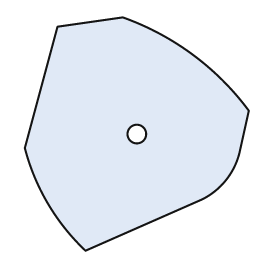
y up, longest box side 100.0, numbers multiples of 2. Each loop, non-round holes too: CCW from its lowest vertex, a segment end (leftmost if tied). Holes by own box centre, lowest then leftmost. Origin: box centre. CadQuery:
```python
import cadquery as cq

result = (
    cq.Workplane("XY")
    .moveTo(-22.0, -50.0)
    .lineTo(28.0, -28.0)
    .threePointArc((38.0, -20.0), (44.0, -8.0))
    .lineTo(48.0, 10.0)
    .threePointArc((24.0, 34.0), (-6.0, 50.0))
    .lineTo(-34.0, 46.0)
    .lineTo(-48.0, -6.0)
    .threePointArc((-38.0, -30.0), (-22.0, -50.0))
    .close()
    .moveTo(0.0, 0.0)
    .circle(4.0)
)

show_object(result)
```